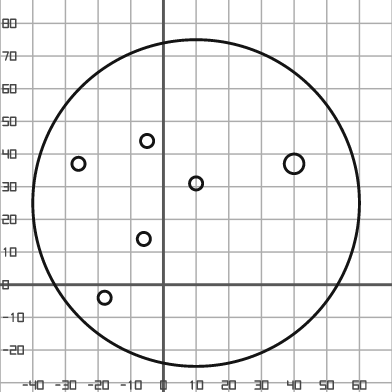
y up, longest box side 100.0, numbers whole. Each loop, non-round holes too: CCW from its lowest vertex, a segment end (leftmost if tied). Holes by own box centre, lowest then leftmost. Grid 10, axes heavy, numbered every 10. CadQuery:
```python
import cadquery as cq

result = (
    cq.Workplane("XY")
    .moveTo(10.0, 25.0)
    .circle(50.0)
    .moveTo(-18.0, -4.0)
    .circle(2.0)
    .moveTo(-6.0, 14.0)
    .circle(2.0)
    .moveTo(10.0, 31.0)
    .circle(2.0)
    .moveTo(-26.0, 37.0)
    .circle(2.0)
    .moveTo(40.0, 37.0)
    .circle(3.0)
    .moveTo(-5.0, 44.0)
    .circle(2.0)
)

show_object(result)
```